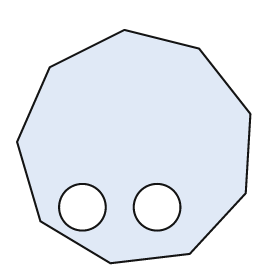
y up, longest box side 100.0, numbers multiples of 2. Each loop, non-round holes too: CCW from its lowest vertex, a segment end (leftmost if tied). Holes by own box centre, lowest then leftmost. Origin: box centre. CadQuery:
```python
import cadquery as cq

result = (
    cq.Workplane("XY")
    .moveTo(-10.0, -50.0)
    .lineTo(24.0, -46.0)
    .lineTo(48.0, -20.0)
    .lineTo(50.0, 14.0)
    .lineTo(28.0, 42.0)
    .lineTo(-4.0, 50.0)
    .lineTo(-36.0, 34.0)
    .lineTo(-50.0, 2.0)
    .lineTo(-40.0, -32.0)
    .close()
    .moveTo(-22.0, -26.0)
    .circle(10.0)
    .moveTo(10.0, -26.0)
    .circle(10.0)
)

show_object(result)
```